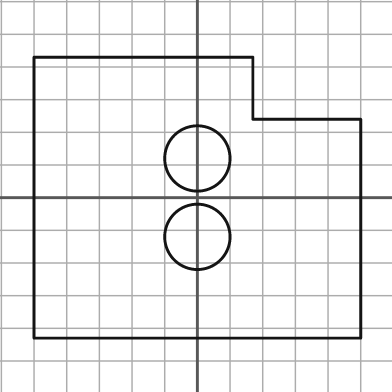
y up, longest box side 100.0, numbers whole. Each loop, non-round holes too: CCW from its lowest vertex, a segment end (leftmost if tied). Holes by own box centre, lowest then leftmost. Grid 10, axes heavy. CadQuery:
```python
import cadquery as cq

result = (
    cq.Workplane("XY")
    .moveTo(-50.0, -43.0)
    .lineTo(50.0, -43.0)
    .lineTo(50.0, 24.0)
    .lineTo(17.0, 24.0)
    .lineTo(17.0, 43.0)
    .lineTo(-50.0, 43.0)
    .close()
    .moveTo(0.0, -12.0)
    .circle(10.0)
    .moveTo(0.0, 12.0)
    .circle(10.0)
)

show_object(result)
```